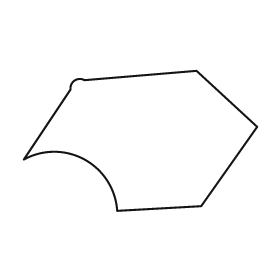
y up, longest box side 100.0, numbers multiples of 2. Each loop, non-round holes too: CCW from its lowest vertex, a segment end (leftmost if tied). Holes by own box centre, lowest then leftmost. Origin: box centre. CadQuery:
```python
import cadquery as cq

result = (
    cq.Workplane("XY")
    .moveTo(-10.0, -30.0)
    .lineTo(26.0, -28.0)
    .lineTo(50.0, 6.0)
    .lineTo(24.0, 30.0)
    .lineTo(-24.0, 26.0)
    .threePointArc((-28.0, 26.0), (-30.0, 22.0))
    .lineTo(-50.0, -8.0)
    .threePointArc((-24.0, -8.0), (-10.0, -30.0))
    .close()
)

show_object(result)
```